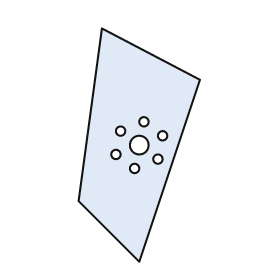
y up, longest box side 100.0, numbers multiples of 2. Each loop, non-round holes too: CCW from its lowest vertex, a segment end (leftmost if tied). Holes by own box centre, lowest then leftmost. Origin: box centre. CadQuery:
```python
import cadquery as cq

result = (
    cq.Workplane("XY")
    .moveTo(0.0, -50.0)
    .lineTo(26.0, 28.0)
    .lineTo(-16.0, 50.0)
    .lineTo(-26.0, -24.0)
    .close()
    .moveTo(-2.0, -10.0)
    .circle(2.0)
    .moveTo(8.0, -6.0)
    .circle(2.0)
    .moveTo(-10.0, -4.0)
    .circle(2.0)
    .moveTo(0.0, 0.0)
    .circle(4.0)
    .moveTo(10.0, 4.0)
    .circle(2.0)
    .moveTo(-8.0, 6.0)
    .circle(2.0)
    .moveTo(2.0, 10.0)
    .circle(2.0)
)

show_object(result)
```